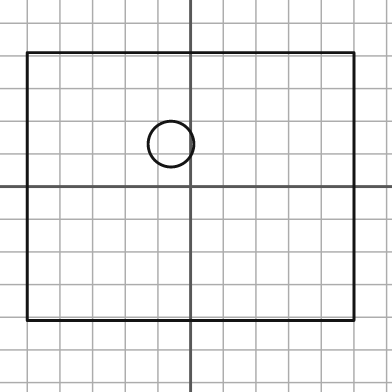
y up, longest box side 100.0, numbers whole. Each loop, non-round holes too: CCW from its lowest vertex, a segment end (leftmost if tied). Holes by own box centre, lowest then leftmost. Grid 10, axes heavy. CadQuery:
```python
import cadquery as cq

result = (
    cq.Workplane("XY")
    .moveTo(-50.0, -41.0)
    .lineTo(50.0, -41.0)
    .lineTo(50.0, 41.0)
    .lineTo(-50.0, 41.0)
    .close()
    .moveTo(-6.0, 13.0)
    .circle(7.0)
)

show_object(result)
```